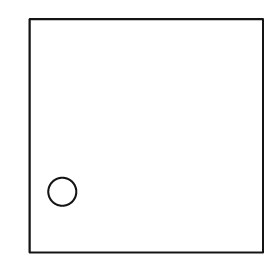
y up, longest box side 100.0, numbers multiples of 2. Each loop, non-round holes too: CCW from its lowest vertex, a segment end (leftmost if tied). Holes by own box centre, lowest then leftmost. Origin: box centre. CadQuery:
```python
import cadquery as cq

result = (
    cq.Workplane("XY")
    .moveTo(-50.0, -50.0)
    .lineTo(50.0, -50.0)
    .lineTo(50.0, 50.0)
    .lineTo(-50.0, 50.0)
    .close()
    .moveTo(-36.0, -24.0)
    .circle(6.0)
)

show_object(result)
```